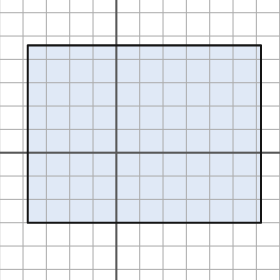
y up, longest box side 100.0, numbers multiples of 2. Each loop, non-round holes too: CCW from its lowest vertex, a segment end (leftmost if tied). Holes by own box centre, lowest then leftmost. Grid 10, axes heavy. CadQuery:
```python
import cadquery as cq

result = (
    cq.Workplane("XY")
    .moveTo(-38.0, -30.0)
    .lineTo(62.0, -30.0)
    .lineTo(62.0, 46.0)
    .lineTo(-38.0, 46.0)
    .close()
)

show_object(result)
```